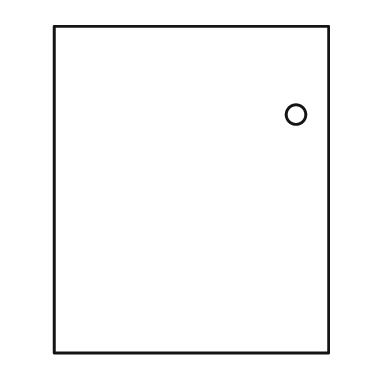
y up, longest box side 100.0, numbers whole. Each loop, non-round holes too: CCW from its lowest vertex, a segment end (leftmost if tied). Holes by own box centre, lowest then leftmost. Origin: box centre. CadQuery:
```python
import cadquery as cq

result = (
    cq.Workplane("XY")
    .moveTo(-42.0, -50.0)
    .lineTo(42.0, -50.0)
    .lineTo(42.0, 50.0)
    .lineTo(-42.0, 50.0)
    .close()
    .moveTo(32.0, 23.0)
    .circle(3.0)
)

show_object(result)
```